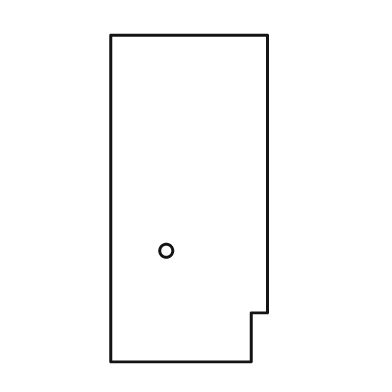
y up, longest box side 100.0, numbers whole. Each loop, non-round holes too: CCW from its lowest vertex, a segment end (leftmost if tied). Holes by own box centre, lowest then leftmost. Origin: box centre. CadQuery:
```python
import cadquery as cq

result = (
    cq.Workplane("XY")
    .moveTo(-24.0, -50.0)
    .lineTo(19.0, -50.0)
    .lineTo(19.0, -35.0)
    .lineTo(24.0, -35.0)
    .lineTo(24.0, 50.0)
    .lineTo(-24.0, 50.0)
    .close()
    .moveTo(-7.0, -16.0)
    .circle(2.0)
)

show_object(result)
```